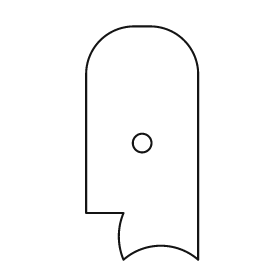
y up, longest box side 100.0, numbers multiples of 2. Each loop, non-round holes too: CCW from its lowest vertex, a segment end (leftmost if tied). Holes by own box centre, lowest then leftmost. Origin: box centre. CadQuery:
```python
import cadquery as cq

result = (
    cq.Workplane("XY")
    .moveTo(-8.0, -50.0)
    .threePointArc((8.0, -44.0), (24.0, -50.0))
    .lineTo(24.0, 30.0)
    .threePointArc((18.0, 44.0), (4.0, 50.0))
    .lineTo(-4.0, 50.0)
    .threePointArc((-18.0, 44.0), (-24.0, 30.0))
    .lineTo(-24.0, -30.0)
    .lineTo(-8.0, -30.0)
    .threePointArc((-10.0, -40.0), (-8.0, -50.0))
    .close()
    .moveTo(0.0, 0.0)
    .circle(4.0)
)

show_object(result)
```